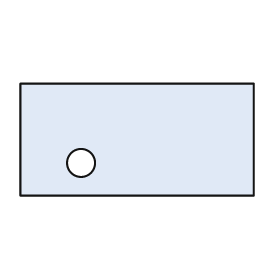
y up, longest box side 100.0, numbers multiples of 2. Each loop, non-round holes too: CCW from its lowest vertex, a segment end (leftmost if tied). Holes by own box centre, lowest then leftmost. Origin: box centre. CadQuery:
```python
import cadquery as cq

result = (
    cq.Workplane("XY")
    .moveTo(-50.0, -24.0)
    .lineTo(50.0, -24.0)
    .lineTo(50.0, 24.0)
    .lineTo(-50.0, 24.0)
    .close()
    .moveTo(-24.0, -10.0)
    .circle(6.0)
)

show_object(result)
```